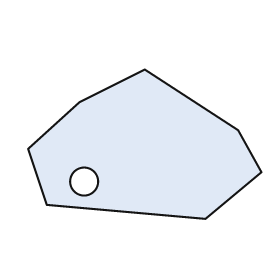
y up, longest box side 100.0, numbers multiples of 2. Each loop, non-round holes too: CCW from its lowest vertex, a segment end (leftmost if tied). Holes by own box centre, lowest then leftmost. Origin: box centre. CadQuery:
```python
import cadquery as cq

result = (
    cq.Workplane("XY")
    .moveTo(26.0, -32.0)
    .lineTo(50.0, -12.0)
    .lineTo(40.0, 6.0)
    .lineTo(0.0, 32.0)
    .lineTo(-28.0, 18.0)
    .lineTo(-50.0, -2.0)
    .lineTo(-42.0, -26.0)
    .close()
    .moveTo(-26.0, -16.0)
    .circle(6.0)
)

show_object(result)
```